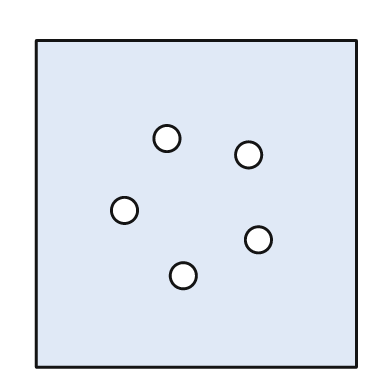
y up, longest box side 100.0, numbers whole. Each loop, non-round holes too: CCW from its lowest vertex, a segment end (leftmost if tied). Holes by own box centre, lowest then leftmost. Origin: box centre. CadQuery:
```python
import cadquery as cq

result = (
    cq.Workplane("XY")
    .moveTo(-49.0, -50.0)
    .lineTo(49.0, -50.0)
    .lineTo(49.0, 50.0)
    .lineTo(-49.0, 50.0)
    .close()
    .moveTo(-4.0, -22.0)
    .circle(4.0)
    .moveTo(19.0, -11.0)
    .circle(4.0)
    .moveTo(-22.0, -2.0)
    .circle(4.0)
    .moveTo(16.0, 15.0)
    .circle(4.0)
    .moveTo(-9.0, 20.0)
    .circle(4.0)
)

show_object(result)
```